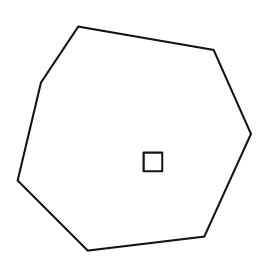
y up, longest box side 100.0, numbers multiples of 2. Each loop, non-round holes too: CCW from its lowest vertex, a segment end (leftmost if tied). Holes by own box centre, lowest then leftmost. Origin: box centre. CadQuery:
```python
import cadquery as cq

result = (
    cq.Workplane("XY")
    .moveTo(-20.0, -48.0)
    .lineTo(30.0, -42.0)
    .lineTo(50.0, 2.0)
    .lineTo(34.0, 38.0)
    .lineTo(-24.0, 48.0)
    .lineTo(-40.0, 24.0)
    .lineTo(-50.0, -18.0)
    .close()
    .moveTo(4.0, -14.0)
    .lineTo(12.0, -14.0)
    .lineTo(12.0, -6.0)
    .lineTo(4.0, -6.0)
    .close()
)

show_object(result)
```